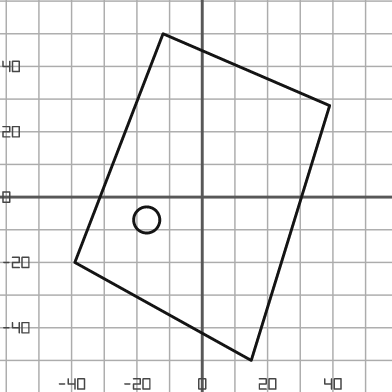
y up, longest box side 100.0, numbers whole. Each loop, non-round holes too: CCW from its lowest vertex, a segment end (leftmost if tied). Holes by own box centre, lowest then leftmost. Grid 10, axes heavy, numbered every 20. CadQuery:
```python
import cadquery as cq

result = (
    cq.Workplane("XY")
    .moveTo(15.0, -50.0)
    .lineTo(39.0, 28.0)
    .lineTo(-12.0, 50.0)
    .lineTo(-39.0, -20.0)
    .close()
    .moveTo(-17.0, -7.0)
    .circle(4.0)
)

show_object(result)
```